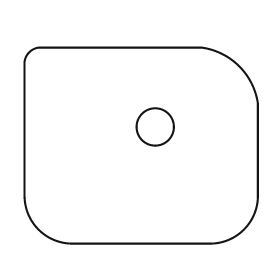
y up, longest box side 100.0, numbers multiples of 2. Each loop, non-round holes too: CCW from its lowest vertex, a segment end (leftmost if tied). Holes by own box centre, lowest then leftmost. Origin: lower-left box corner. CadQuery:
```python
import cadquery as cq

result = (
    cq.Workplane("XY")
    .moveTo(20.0, 0.0)
    .lineTo(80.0, 0.0)
    .threePointArc((94.0, 6.0), (100.0, 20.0))
    .lineTo(100.0, 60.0)
    .threePointArc((92.0, 76.0), (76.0, 84.0))
    .lineTo(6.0, 84.0)
    .threePointArc((2.0, 82.0), (0.0, 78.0))
    .lineTo(0.0, 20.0)
    .threePointArc((6.0, 6.0), (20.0, 0.0))
    .close()
    .moveTo(56.0, 50.0)
    .circle(8.0)
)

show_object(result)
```